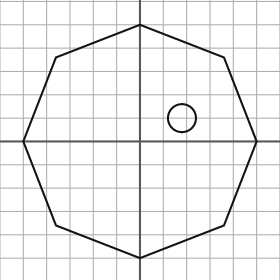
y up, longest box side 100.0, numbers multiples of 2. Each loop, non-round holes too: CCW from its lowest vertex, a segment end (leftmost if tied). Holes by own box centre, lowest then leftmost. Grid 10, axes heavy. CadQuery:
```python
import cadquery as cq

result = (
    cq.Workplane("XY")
    .moveTo(0.0, -50.0)
    .lineTo(36.0, -36.0)
    .lineTo(50.0, 0.0)
    .lineTo(36.0, 36.0)
    .lineTo(0.0, 50.0)
    .lineTo(-36.0, 36.0)
    .lineTo(-50.0, 0.0)
    .lineTo(-36.0, -36.0)
    .close()
    .moveTo(18.0, 10.0)
    .circle(6.0)
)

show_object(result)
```